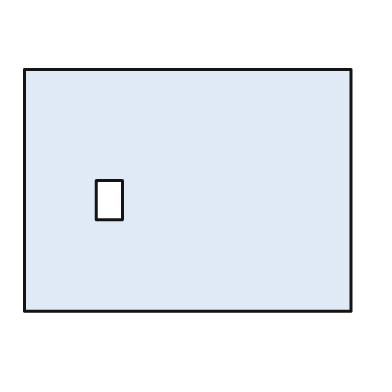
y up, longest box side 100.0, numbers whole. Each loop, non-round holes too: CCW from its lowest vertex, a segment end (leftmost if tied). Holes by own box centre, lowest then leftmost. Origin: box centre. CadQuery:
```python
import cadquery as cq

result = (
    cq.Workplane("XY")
    .moveTo(-50.0, -37.0)
    .lineTo(50.0, -37.0)
    .lineTo(50.0, 37.0)
    .lineTo(-50.0, 37.0)
    .close()
    .moveTo(-28.0, -9.0)
    .lineTo(-20.0, -9.0)
    .lineTo(-20.0, 3.0)
    .lineTo(-28.0, 3.0)
    .close()
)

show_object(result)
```